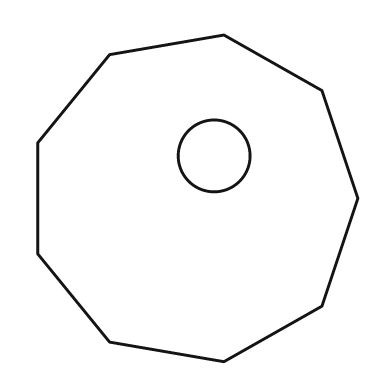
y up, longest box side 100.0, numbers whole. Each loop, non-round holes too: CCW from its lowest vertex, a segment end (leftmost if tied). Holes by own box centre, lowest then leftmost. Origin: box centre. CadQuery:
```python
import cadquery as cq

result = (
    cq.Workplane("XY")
    .moveTo(8.0, -50.0)
    .lineTo(38.0, -33.0)
    .lineTo(49.0, 0.0)
    .lineTo(38.0, 33.0)
    .lineTo(8.0, 50.0)
    .lineTo(-27.0, 44.0)
    .lineTo(-49.0, 17.0)
    .lineTo(-49.0, -17.0)
    .lineTo(-27.0, -44.0)
    .close()
    .moveTo(5.0, 13.0)
    .circle(11.0)
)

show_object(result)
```